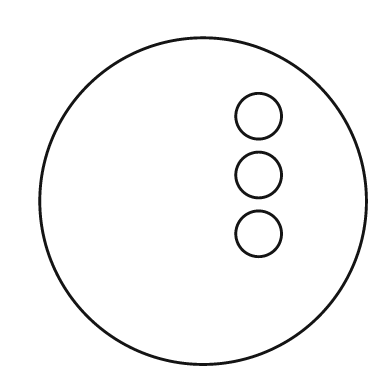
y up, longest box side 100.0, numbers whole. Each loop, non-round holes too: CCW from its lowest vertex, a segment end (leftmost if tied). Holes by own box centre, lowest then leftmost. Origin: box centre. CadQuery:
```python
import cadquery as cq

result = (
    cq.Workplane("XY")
    .moveTo(0.0, 0.0)
    .circle(50.0)
    .moveTo(17.0, -10.0)
    .circle(7.0)
    .moveTo(17.0, 8.0)
    .circle(7.0)
    .moveTo(17.0, 26.0)
    .circle(7.0)
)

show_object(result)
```